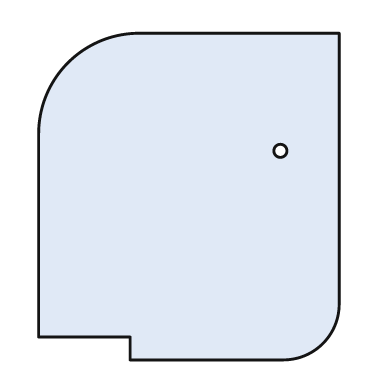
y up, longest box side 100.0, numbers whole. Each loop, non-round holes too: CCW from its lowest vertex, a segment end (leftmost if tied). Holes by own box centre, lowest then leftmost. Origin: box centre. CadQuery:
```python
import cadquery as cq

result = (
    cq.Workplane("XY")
    .moveTo(-18.0, -50.0)
    .lineTo(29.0, -50.0)
    .threePointArc((41.0, -45.0), (46.0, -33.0))
    .lineTo(46.0, 50.0)
    .lineTo(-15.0, 50.0)
    .threePointArc((-37.0, 41.0), (-46.0, 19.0))
    .lineTo(-46.0, -43.0)
    .lineTo(-18.0, -43.0)
    .close()
    .moveTo(28.0, 14.0)
    .circle(2.0)
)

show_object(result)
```